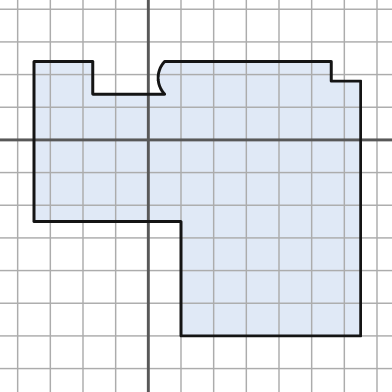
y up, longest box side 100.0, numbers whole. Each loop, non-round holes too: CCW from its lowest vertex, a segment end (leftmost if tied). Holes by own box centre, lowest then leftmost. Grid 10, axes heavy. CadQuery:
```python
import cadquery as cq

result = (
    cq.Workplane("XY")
    .moveTo(10.0, -60.0)
    .lineTo(65.0, -60.0)
    .lineTo(65.0, 18.0)
    .lineTo(56.0, 18.0)
    .lineTo(56.0, 24.0)
    .lineTo(5.0, 24.0)
    .threePointArc((3.0, 19.0), (5.0, 14.0))
    .lineTo(-17.0, 14.0)
    .lineTo(-17.0, 24.0)
    .lineTo(-35.0, 24.0)
    .lineTo(-35.0, -25.0)
    .lineTo(10.0, -25.0)
    .close()
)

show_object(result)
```